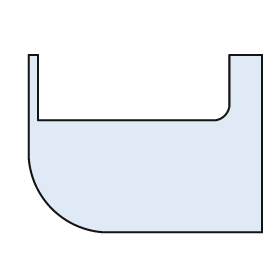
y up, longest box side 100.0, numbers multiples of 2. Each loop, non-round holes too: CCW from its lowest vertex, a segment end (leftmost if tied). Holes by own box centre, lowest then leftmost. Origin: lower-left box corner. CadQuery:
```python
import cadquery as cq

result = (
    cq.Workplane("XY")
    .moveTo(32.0, 0.0)
    .lineTo(100.0, 0.0)
    .lineTo(100.0, 76.0)
    .lineTo(86.0, 76.0)
    .lineTo(86.0, 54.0)
    .threePointArc((84.0, 50.0), (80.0, 48.0))
    .lineTo(4.0, 48.0)
    .lineTo(4.0, 76.0)
    .lineTo(0.0, 76.0)
    .lineTo(0.0, 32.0)
    .threePointArc((10.0, 10.0), (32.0, 0.0))
    .close()
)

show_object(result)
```